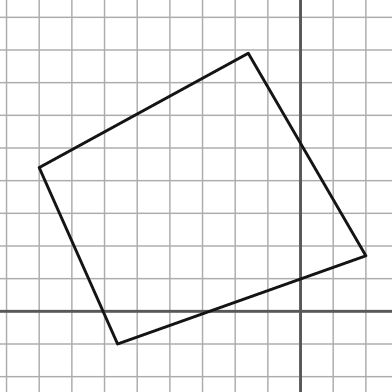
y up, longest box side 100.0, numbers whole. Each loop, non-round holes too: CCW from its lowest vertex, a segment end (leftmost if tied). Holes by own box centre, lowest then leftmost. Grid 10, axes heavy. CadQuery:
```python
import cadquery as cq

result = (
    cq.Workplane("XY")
    .moveTo(-56.0, -10.0)
    .lineTo(20.0, 17.0)
    .lineTo(-16.0, 79.0)
    .lineTo(-80.0, 44.0)
    .close()
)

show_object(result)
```